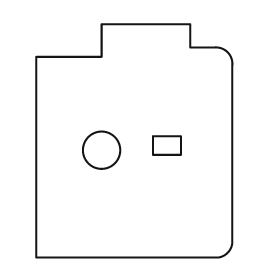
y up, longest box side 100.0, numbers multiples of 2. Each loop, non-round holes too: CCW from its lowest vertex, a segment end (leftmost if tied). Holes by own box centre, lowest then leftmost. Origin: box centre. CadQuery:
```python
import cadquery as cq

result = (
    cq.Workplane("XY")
    .moveTo(-42.0, -50.0)
    .lineTo(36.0, -50.0)
    .threePointArc((40.0, -48.0), (42.0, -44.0))
    .lineTo(42.0, 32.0)
    .threePointArc((40.0, 38.0), (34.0, 40.0))
    .lineTo(24.0, 40.0)
    .lineTo(24.0, 50.0)
    .lineTo(-14.0, 50.0)
    .lineTo(-14.0, 36.0)
    .lineTo(-42.0, 36.0)
    .close()
    .moveTo(-14.0, -4.0)
    .circle(8.0)
    .moveTo(8.0, -6.0)
    .lineTo(20.0, -6.0)
    .lineTo(20.0, 2.0)
    .lineTo(8.0, 2.0)
    .close()
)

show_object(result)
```